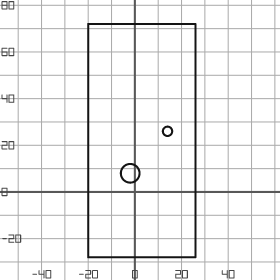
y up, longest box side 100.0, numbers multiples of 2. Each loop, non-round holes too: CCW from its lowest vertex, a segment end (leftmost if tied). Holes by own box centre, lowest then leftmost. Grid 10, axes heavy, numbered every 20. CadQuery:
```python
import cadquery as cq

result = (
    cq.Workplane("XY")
    .moveTo(-20.0, -28.0)
    .lineTo(26.0, -28.0)
    .lineTo(26.0, 72.0)
    .lineTo(-20.0, 72.0)
    .close()
    .moveTo(-2.0, 8.0)
    .circle(4.0)
    .moveTo(14.0, 26.0)
    .circle(2.0)
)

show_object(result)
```